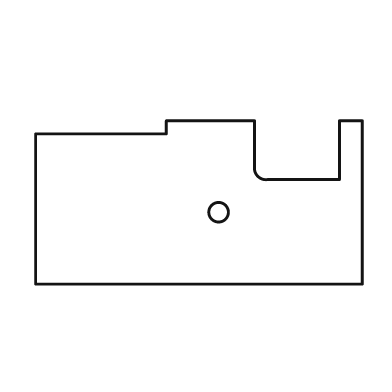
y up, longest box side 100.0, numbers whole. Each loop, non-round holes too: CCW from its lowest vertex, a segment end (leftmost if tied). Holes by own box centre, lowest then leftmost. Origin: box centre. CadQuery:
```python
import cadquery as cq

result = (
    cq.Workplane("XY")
    .moveTo(-50.0, -25.0)
    .lineTo(50.0, -25.0)
    .lineTo(50.0, 25.0)
    .lineTo(43.0, 25.0)
    .lineTo(43.0, 7.0)
    .lineTo(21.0, 7.0)
    .threePointArc((18.0, 8.0), (17.0, 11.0))
    .lineTo(17.0, 25.0)
    .lineTo(-10.0, 25.0)
    .lineTo(-10.0, 21.0)
    .lineTo(-50.0, 21.0)
    .close()
    .moveTo(6.0, -3.0)
    .circle(3.0)
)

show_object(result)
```